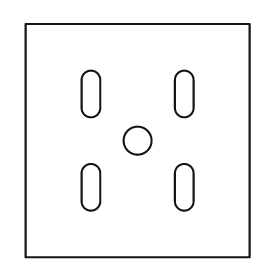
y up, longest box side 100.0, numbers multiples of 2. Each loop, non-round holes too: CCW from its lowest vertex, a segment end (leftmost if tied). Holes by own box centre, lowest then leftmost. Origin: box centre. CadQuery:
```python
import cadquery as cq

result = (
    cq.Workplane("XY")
    .moveTo(-48.0, -50.0)
    .lineTo(48.0, -50.0)
    .lineTo(48.0, 50.0)
    .lineTo(-48.0, 50.0)
    .close()
    .moveTo(-24.0, -26.0)
    .threePointArc((-20.0, -30.0), (-16.0, -26.0))
    .lineTo(-16.0, -14.0)
    .threePointArc((-20.0, -10.0), (-24.0, -14.0))
    .close()
    .moveTo(16.0, -26.0)
    .threePointArc((20.0, -30.0), (24.0, -26.0))
    .lineTo(24.0, -14.0)
    .threePointArc((20.0, -10.0), (16.0, -14.0))
    .close()
    .moveTo(0.0, 0.0)
    .circle(6.0)
    .moveTo(-24.0, 14.0)
    .threePointArc((-20.0, 10.0), (-16.0, 14.0))
    .lineTo(-16.0, 26.0)
    .threePointArc((-20.0, 30.0), (-24.0, 26.0))
    .close()
    .moveTo(16.0, 14.0)
    .threePointArc((20.0, 10.0), (24.0, 14.0))
    .lineTo(24.0, 26.0)
    .threePointArc((20.0, 30.0), (16.0, 26.0))
    .close()
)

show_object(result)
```